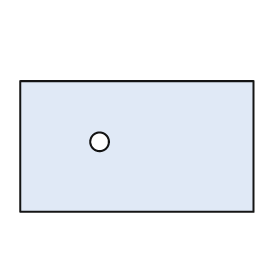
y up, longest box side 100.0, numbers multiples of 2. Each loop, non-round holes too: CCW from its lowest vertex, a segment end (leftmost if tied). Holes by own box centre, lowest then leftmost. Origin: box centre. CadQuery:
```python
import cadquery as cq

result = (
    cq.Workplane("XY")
    .moveTo(-50.0, -28.0)
    .lineTo(50.0, -28.0)
    .lineTo(50.0, 28.0)
    .lineTo(-50.0, 28.0)
    .close()
    .moveTo(-16.0, 2.0)
    .circle(4.0)
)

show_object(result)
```